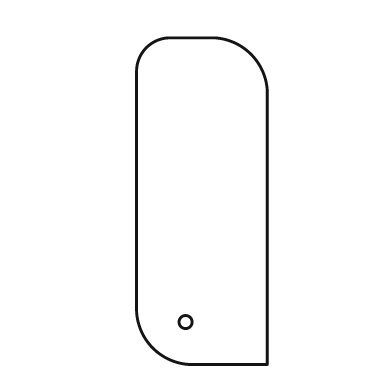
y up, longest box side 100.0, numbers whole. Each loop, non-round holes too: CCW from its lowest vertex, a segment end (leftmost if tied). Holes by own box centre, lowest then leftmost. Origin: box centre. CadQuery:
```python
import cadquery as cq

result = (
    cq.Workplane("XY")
    .moveTo(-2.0, -50.0)
    .lineTo(20.0, -50.0)
    .lineTo(20.0, 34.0)
    .threePointArc((15.0, 45.0), (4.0, 50.0))
    .lineTo(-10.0, 50.0)
    .threePointArc((-17.0, 47.0), (-20.0, 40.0))
    .lineTo(-20.0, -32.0)
    .threePointArc((-15.0, -45.0), (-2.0, -50.0))
    .close()
    .moveTo(-5.0, -37.0)
    .circle(2.0)
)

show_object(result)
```